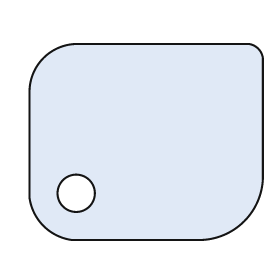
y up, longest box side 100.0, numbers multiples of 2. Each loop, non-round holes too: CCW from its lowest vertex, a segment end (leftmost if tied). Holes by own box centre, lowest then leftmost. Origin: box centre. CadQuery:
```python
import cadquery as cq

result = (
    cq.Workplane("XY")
    .moveTo(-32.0, -42.0)
    .lineTo(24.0, -42.0)
    .threePointArc((42.0, -34.0), (50.0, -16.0))
    .lineTo(50.0, 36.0)
    .threePointArc((48.0, 40.0), (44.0, 42.0))
    .lineTo(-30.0, 42.0)
    .threePointArc((-44.0, 36.0), (-50.0, 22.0))
    .lineTo(-50.0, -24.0)
    .threePointArc((-44.0, -36.0), (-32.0, -42.0))
    .close()
    .moveTo(-30.0, -22.0)
    .circle(8.0)
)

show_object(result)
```